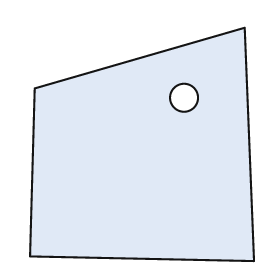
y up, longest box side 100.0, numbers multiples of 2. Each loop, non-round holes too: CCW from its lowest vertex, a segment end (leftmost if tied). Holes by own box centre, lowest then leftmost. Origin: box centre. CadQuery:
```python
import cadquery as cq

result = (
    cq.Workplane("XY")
    .moveTo(48.0, -50.0)
    .lineTo(44.0, 50.0)
    .lineTo(-46.0, 24.0)
    .lineTo(-48.0, -48.0)
    .close()
    .moveTo(18.0, 20.0)
    .circle(6.0)
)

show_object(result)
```